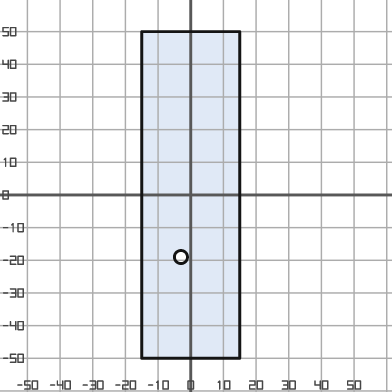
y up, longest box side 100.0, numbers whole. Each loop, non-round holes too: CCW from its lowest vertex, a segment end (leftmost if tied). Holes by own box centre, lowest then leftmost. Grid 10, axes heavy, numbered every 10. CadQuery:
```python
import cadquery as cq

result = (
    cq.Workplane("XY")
    .moveTo(-15.0, -50.0)
    .lineTo(15.0, -50.0)
    .lineTo(15.0, 50.0)
    .lineTo(-15.0, 50.0)
    .close()
    .moveTo(-3.0, -19.0)
    .circle(2.0)
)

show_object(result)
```